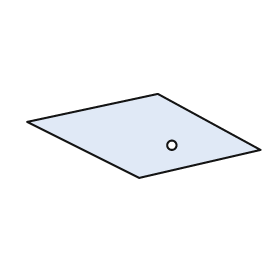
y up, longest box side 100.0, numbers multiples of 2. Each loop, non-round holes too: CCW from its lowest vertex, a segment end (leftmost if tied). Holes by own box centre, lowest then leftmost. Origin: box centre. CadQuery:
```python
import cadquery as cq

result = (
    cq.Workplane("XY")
    .moveTo(-2.0, -18.0)
    .lineTo(50.0, -6.0)
    .lineTo(6.0, 18.0)
    .lineTo(-50.0, 6.0)
    .close()
    .moveTo(12.0, -4.0)
    .circle(2.0)
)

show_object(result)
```